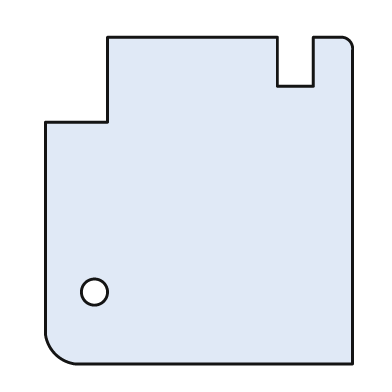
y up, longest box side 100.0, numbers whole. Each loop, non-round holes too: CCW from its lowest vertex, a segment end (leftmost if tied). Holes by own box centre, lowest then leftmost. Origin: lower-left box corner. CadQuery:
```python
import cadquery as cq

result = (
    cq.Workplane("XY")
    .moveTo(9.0, 0.0)
    .lineTo(94.0, 0.0)
    .lineTo(94.0, 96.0)
    .threePointArc((93.0, 99.0), (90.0, 100.0))
    .lineTo(82.0, 100.0)
    .lineTo(82.0, 85.0)
    .lineTo(71.0, 85.0)
    .lineTo(71.0, 100.0)
    .lineTo(19.0, 100.0)
    .lineTo(19.0, 74.0)
    .lineTo(0.0, 74.0)
    .lineTo(0.0, 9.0)
    .threePointArc((3.0, 3.0), (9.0, 0.0))
    .close()
    .moveTo(15.0, 22.0)
    .circle(4.0)
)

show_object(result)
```